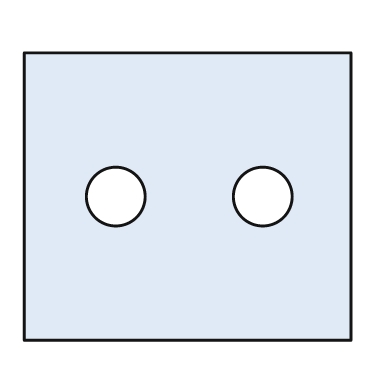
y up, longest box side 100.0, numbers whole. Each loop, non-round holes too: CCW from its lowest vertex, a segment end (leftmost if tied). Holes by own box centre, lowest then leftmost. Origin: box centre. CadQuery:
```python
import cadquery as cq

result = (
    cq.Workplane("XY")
    .moveTo(-50.0, -44.0)
    .lineTo(50.0, -44.0)
    .lineTo(50.0, 44.0)
    .lineTo(-50.0, 44.0)
    .close()
    .moveTo(-22.0, 0.0)
    .circle(9.0)
    .moveTo(23.0, 0.0)
    .circle(9.0)
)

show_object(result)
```